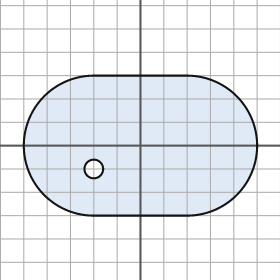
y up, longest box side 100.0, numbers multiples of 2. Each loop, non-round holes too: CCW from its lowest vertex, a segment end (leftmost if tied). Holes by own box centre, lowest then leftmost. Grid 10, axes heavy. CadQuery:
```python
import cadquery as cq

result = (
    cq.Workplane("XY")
    .moveTo(-20.0, -30.0)
    .lineTo(20.0, -30.0)
    .threePointArc((50.0, 0.0), (20.0, 30.0))
    .lineTo(-20.0, 30.0)
    .threePointArc((-50.0, 0.0), (-20.0, -30.0))
    .close()
    .moveTo(-20.0, -10.0)
    .circle(4.0)
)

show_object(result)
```